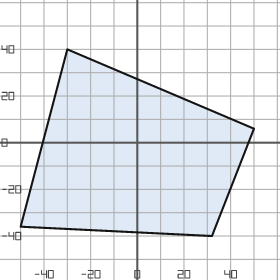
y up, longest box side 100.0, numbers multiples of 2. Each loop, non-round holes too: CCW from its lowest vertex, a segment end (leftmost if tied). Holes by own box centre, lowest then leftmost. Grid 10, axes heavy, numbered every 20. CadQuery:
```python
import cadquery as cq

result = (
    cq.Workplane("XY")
    .moveTo(32.0, -40.0)
    .lineTo(50.0, 6.0)
    .lineTo(-30.0, 40.0)
    .lineTo(-50.0, -36.0)
    .close()
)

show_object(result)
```